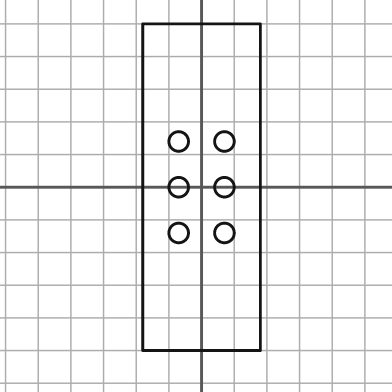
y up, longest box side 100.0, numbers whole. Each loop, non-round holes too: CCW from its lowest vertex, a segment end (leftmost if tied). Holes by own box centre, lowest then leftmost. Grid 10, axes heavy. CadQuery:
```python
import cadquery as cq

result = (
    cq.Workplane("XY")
    .moveTo(-18.0, -50.0)
    .lineTo(18.0, -50.0)
    .lineTo(18.0, 50.0)
    .lineTo(-18.0, 50.0)
    .close()
    .moveTo(-7.0, -14.0)
    .circle(3.0)
    .moveTo(7.0, -14.0)
    .circle(3.0)
    .moveTo(-7.0, 0.0)
    .circle(3.0)
    .moveTo(7.0, 0.0)
    .circle(3.0)
    .moveTo(-7.0, 14.0)
    .circle(3.0)
    .moveTo(7.0, 14.0)
    .circle(3.0)
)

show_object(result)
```